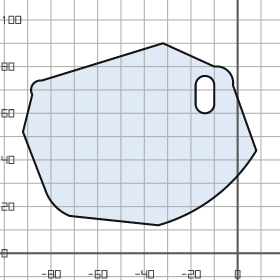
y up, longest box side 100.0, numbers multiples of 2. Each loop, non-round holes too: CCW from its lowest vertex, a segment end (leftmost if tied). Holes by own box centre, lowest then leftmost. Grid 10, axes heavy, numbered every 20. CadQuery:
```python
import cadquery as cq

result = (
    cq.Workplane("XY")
    .moveTo(-34.0, 12.0)
    .threePointArc((-10.0, 24.0), (8.0, 44.0))
    .lineTo(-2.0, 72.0)
    .threePointArc((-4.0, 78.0), (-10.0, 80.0))
    .lineTo(-32.0, 90.0)
    .lineTo(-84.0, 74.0)
    .threePointArc((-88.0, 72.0), (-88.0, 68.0))
    .lineTo(-92.0, 52.0)
    .lineTo(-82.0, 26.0)
    .threePointArc((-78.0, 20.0), (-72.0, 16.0))
    .close()
    .moveTo(-18.0, 64.0)
    .threePointArc((-14.0, 60.0), (-10.0, 64.0))
    .lineTo(-10.0, 72.0)
    .threePointArc((-14.0, 76.0), (-18.0, 72.0))
    .close()
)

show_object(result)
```